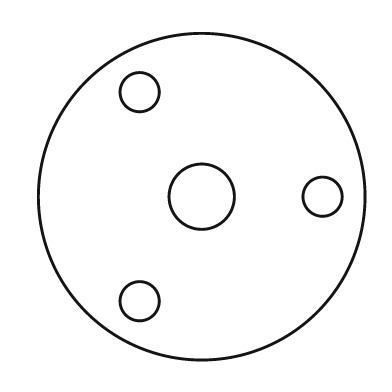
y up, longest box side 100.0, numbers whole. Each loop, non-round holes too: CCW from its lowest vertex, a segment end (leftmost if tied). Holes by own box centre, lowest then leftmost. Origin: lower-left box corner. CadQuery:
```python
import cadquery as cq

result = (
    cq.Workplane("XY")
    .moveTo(50.0, 50.0)
    .circle(50.0)
    .moveTo(31.0, 18.0)
    .circle(6.0)
    .moveTo(50.0, 50.0)
    .circle(10.0)
    .moveTo(87.0, 50.0)
    .circle(6.0)
    .moveTo(31.0, 82.0)
    .circle(6.0)
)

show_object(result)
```